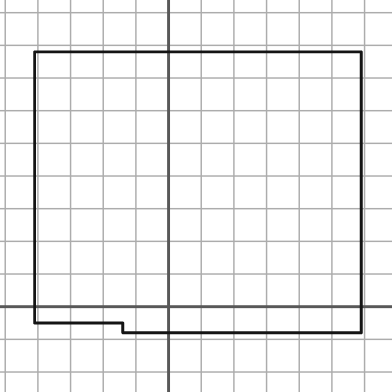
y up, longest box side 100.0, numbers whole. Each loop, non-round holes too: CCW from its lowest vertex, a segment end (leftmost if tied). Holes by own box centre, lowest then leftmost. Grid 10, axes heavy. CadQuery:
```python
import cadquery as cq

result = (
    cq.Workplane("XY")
    .moveTo(-14.0, -8.0)
    .lineTo(59.0, -8.0)
    .lineTo(59.0, 78.0)
    .lineTo(-41.0, 78.0)
    .lineTo(-41.0, -5.0)
    .lineTo(-14.0, -5.0)
    .close()
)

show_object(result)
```